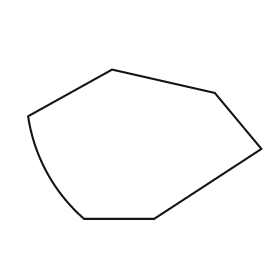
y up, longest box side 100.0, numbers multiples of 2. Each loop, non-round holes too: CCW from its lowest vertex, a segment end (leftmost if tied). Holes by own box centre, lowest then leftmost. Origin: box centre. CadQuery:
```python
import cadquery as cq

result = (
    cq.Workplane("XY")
    .moveTo(-26.0, -32.0)
    .lineTo(4.0, -32.0)
    .lineTo(50.0, -2.0)
    .lineTo(30.0, 22.0)
    .lineTo(-14.0, 32.0)
    .lineTo(-50.0, 12.0)
    .threePointArc((-42.0, -12.0), (-26.0, -32.0))
    .close()
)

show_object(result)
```